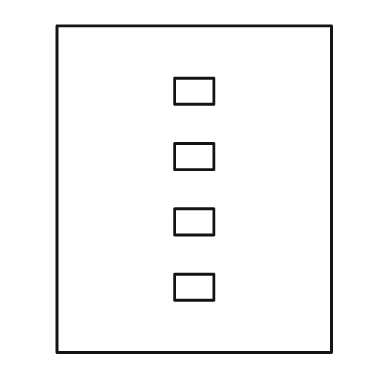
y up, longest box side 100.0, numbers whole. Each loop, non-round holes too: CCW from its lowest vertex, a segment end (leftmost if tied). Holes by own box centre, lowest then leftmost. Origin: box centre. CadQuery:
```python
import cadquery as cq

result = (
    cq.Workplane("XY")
    .moveTo(-42.0, -50.0)
    .lineTo(42.0, -50.0)
    .lineTo(42.0, 50.0)
    .lineTo(-42.0, 50.0)
    .close()
    .moveTo(-6.0, -34.0)
    .lineTo(6.0, -34.0)
    .lineTo(6.0, -26.0)
    .lineTo(-6.0, -26.0)
    .close()
    .moveTo(-6.0, -14.0)
    .lineTo(6.0, -14.0)
    .lineTo(6.0, -6.0)
    .lineTo(-6.0, -6.0)
    .close()
    .moveTo(-6.0, 6.0)
    .lineTo(6.0, 6.0)
    .lineTo(6.0, 14.0)
    .lineTo(-6.0, 14.0)
    .close()
    .moveTo(-6.0, 26.0)
    .lineTo(6.0, 26.0)
    .lineTo(6.0, 34.0)
    .lineTo(-6.0, 34.0)
    .close()
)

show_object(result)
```